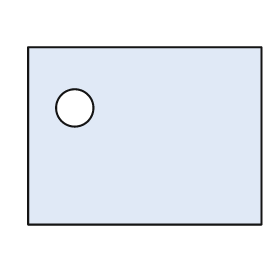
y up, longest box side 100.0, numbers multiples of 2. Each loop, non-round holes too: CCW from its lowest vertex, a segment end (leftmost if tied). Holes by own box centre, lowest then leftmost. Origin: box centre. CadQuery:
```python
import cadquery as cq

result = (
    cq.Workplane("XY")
    .moveTo(-50.0, -38.0)
    .lineTo(50.0, -38.0)
    .lineTo(50.0, 38.0)
    .lineTo(-50.0, 38.0)
    .close()
    .moveTo(-30.0, 12.0)
    .circle(8.0)
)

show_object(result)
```